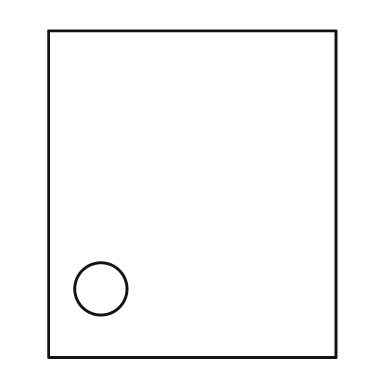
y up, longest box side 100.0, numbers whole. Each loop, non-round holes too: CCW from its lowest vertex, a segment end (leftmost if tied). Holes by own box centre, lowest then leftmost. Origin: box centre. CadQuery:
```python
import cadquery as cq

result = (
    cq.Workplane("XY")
    .moveTo(-44.0, -50.0)
    .lineTo(44.0, -50.0)
    .lineTo(44.0, 50.0)
    .lineTo(-44.0, 50.0)
    .close()
    .moveTo(-28.0, -29.0)
    .circle(8.0)
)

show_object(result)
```